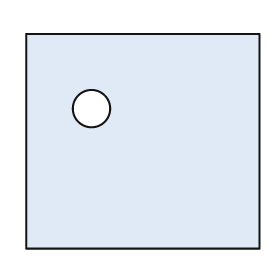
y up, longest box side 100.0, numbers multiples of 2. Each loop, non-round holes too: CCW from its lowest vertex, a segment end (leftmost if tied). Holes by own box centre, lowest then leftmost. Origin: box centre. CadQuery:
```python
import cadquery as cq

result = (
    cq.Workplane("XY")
    .moveTo(-50.0, -46.0)
    .lineTo(50.0, -46.0)
    .lineTo(50.0, 46.0)
    .lineTo(-50.0, 46.0)
    .close()
    .moveTo(-22.0, 14.0)
    .circle(8.0)
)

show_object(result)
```